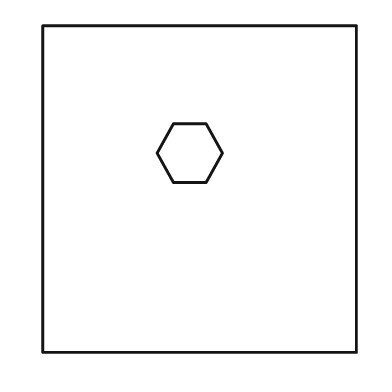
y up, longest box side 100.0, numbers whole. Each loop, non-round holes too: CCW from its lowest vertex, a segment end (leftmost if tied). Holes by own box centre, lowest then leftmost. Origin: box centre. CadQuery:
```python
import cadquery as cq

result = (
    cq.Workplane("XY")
    .moveTo(-48.0, -50.0)
    .lineTo(48.0, -50.0)
    .lineTo(48.0, 50.0)
    .lineTo(-48.0, 50.0)
    .close()
    .moveTo(-8.0, 2.0)
    .lineTo(2.0, 2.0)
    .lineTo(7.0, 11.0)
    .lineTo(2.0, 20.0)
    .lineTo(-8.0, 20.0)
    .lineTo(-13.0, 11.0)
    .close()
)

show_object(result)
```